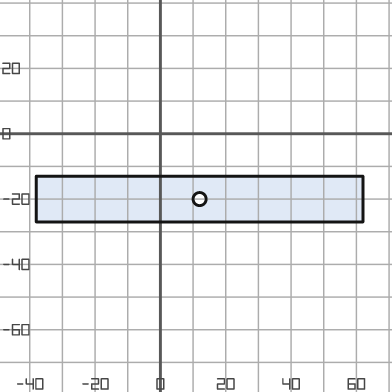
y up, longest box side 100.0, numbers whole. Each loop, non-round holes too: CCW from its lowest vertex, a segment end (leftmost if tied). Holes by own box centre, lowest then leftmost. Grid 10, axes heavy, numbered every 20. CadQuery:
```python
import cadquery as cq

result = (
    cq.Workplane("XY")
    .moveTo(-38.0, -27.0)
    .lineTo(62.0, -27.0)
    .lineTo(62.0, -13.0)
    .lineTo(-38.0, -13.0)
    .close()
    .moveTo(12.0, -20.0)
    .circle(2.0)
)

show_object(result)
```